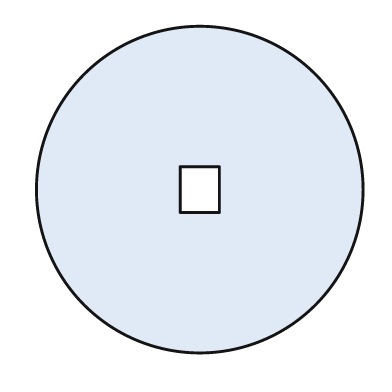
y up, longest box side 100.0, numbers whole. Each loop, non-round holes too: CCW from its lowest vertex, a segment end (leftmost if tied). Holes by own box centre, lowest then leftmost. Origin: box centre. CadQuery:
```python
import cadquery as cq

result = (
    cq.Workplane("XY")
    .moveTo(0.0, 0.0)
    .circle(50.0)
    .moveTo(-6.0, -7.0)
    .lineTo(6.0, -7.0)
    .lineTo(6.0, 7.0)
    .lineTo(-6.0, 7.0)
    .close()
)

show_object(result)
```